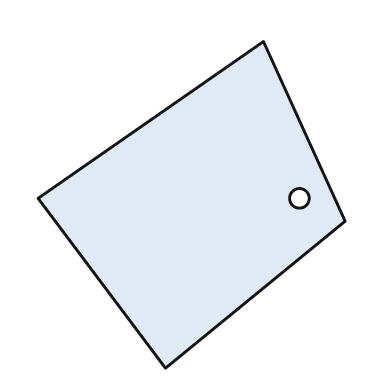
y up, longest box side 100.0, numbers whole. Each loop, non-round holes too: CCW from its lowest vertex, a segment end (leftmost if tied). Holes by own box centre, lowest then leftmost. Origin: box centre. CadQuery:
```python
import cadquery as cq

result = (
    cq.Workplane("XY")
    .moveTo(-8.0, -50.0)
    .lineTo(47.0, -5.0)
    .lineTo(22.0, 50.0)
    .lineTo(-47.0, 2.0)
    .close()
    .moveTo(33.0, 2.0)
    .circle(3.0)
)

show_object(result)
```